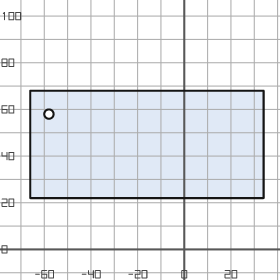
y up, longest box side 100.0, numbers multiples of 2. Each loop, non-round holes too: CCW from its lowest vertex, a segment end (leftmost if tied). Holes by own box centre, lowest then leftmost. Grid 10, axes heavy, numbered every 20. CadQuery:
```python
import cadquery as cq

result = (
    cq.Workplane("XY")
    .moveTo(-66.0, 22.0)
    .lineTo(34.0, 22.0)
    .lineTo(34.0, 68.0)
    .lineTo(-66.0, 68.0)
    .close()
    .moveTo(-58.0, 58.0)
    .circle(2.0)
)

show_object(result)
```